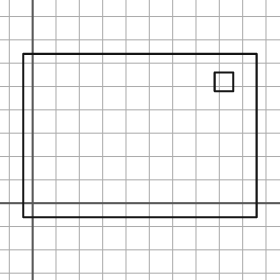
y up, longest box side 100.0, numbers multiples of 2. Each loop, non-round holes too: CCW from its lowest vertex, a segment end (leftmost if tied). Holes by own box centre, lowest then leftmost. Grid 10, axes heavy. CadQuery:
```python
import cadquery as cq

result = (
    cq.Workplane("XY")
    .moveTo(-4.0, -6.0)
    .lineTo(96.0, -6.0)
    .lineTo(96.0, 64.0)
    .lineTo(-4.0, 64.0)
    .close()
    .moveTo(78.0, 48.0)
    .lineTo(86.0, 48.0)
    .lineTo(86.0, 56.0)
    .lineTo(78.0, 56.0)
    .close()
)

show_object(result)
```